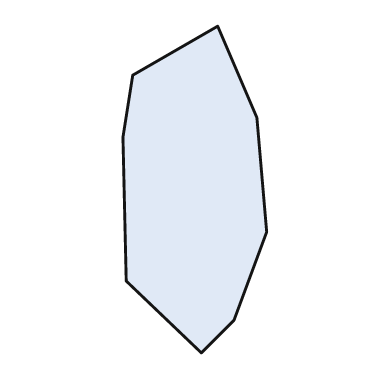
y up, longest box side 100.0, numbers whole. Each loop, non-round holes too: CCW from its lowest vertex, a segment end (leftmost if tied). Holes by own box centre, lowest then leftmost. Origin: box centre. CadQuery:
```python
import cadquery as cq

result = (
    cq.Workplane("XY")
    .moveTo(2.0, -50.0)
    .lineTo(12.0, -40.0)
    .lineTo(22.0, -13.0)
    .lineTo(19.0, 22.0)
    .lineTo(7.0, 50.0)
    .lineTo(-19.0, 35.0)
    .lineTo(-22.0, 16.0)
    .lineTo(-21.0, -28.0)
    .close()
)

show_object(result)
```